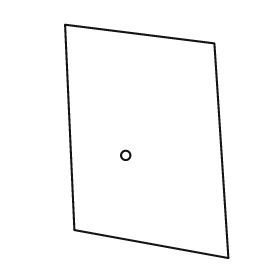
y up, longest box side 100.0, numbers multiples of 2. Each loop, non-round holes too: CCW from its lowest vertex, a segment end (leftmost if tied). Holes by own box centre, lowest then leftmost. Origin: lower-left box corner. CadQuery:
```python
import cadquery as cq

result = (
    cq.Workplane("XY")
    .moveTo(70.0, 0.0)
    .lineTo(64.0, 92.0)
    .lineTo(0.0, 100.0)
    .lineTo(4.0, 12.0)
    .close()
    .moveTo(26.0, 44.0)
    .circle(2.0)
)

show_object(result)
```